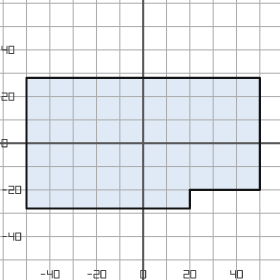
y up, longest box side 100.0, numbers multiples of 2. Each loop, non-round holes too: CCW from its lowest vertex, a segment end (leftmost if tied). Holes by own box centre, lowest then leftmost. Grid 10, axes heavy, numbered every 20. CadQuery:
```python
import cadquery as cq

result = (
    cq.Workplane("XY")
    .moveTo(-50.0, -28.0)
    .lineTo(20.0, -28.0)
    .lineTo(20.0, -20.0)
    .lineTo(50.0, -20.0)
    .lineTo(50.0, 28.0)
    .lineTo(-50.0, 28.0)
    .close()
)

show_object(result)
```